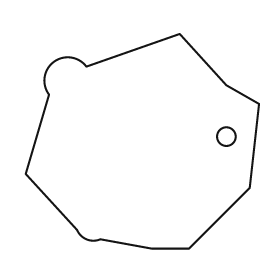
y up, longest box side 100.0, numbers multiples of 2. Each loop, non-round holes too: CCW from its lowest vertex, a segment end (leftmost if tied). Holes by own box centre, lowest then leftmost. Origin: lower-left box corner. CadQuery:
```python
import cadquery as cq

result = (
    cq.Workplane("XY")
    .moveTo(54.0, 0.0)
    .lineTo(70.0, 0.0)
    .lineTo(96.0, 26.0)
    .lineTo(100.0, 62.0)
    .lineTo(86.0, 70.0)
    .lineTo(66.0, 92.0)
    .lineTo(26.0, 78.0)
    .threePointArc((12.0, 80.0), (10.0, 66.0))
    .lineTo(0.0, 32.0)
    .lineTo(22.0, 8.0)
    .threePointArc((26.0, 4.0), (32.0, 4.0))
    .close()
    .moveTo(86.0, 48.0)
    .circle(4.0)
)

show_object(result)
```